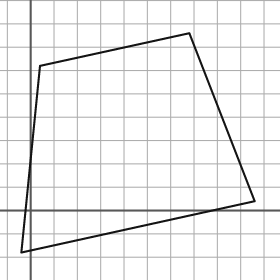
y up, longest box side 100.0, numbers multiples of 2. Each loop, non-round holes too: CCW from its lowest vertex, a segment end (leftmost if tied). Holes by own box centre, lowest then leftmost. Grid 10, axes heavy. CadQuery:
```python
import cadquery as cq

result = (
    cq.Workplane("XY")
    .moveTo(-4.0, -18.0)
    .lineTo(96.0, 4.0)
    .lineTo(68.0, 76.0)
    .lineTo(4.0, 62.0)
    .close()
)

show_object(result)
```